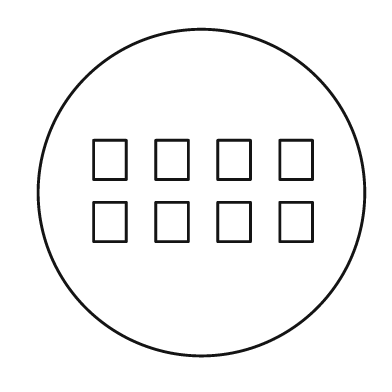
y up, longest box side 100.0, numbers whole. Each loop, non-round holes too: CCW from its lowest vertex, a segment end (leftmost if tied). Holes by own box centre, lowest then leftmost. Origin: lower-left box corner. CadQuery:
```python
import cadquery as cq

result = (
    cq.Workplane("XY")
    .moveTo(50.0, 50.0)
    .circle(50.0)
    .moveTo(17.0, 35.0)
    .lineTo(27.0, 35.0)
    .lineTo(27.0, 47.0)
    .lineTo(17.0, 47.0)
    .close()
    .moveTo(36.0, 35.0)
    .lineTo(46.0, 35.0)
    .lineTo(46.0, 47.0)
    .lineTo(36.0, 47.0)
    .close()
    .moveTo(55.0, 35.0)
    .lineTo(65.0, 35.0)
    .lineTo(65.0, 47.0)
    .lineTo(55.0, 47.0)
    .close()
    .moveTo(74.0, 35.0)
    .lineTo(84.0, 35.0)
    .lineTo(84.0, 47.0)
    .lineTo(74.0, 47.0)
    .close()
    .moveTo(17.0, 54.0)
    .lineTo(27.0, 54.0)
    .lineTo(27.0, 66.0)
    .lineTo(17.0, 66.0)
    .close()
    .moveTo(36.0, 54.0)
    .lineTo(46.0, 54.0)
    .lineTo(46.0, 66.0)
    .lineTo(36.0, 66.0)
    .close()
    .moveTo(55.0, 54.0)
    .lineTo(65.0, 54.0)
    .lineTo(65.0, 66.0)
    .lineTo(55.0, 66.0)
    .close()
    .moveTo(74.0, 54.0)
    .lineTo(84.0, 54.0)
    .lineTo(84.0, 66.0)
    .lineTo(74.0, 66.0)
    .close()
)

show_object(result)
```